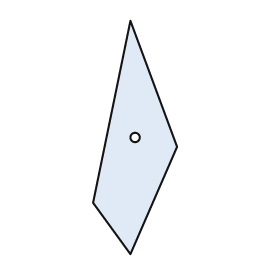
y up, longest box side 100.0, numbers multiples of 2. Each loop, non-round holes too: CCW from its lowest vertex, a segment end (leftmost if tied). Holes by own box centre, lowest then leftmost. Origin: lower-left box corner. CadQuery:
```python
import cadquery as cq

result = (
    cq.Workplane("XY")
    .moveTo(16.0, 0.0)
    .lineTo(36.0, 46.0)
    .lineTo(16.0, 100.0)
    .lineTo(0.0, 22.0)
    .close()
    .moveTo(18.0, 50.0)
    .circle(2.0)
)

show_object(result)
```